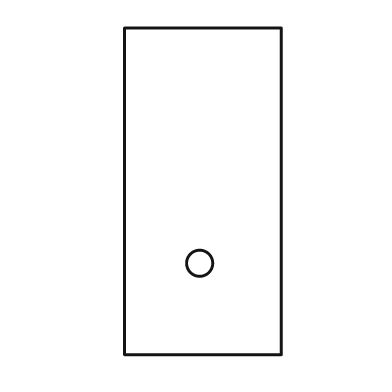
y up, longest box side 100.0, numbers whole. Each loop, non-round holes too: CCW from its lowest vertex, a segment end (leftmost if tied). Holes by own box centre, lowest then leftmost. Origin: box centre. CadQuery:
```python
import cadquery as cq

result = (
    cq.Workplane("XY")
    .moveTo(-24.0, -50.0)
    .lineTo(24.0, -50.0)
    .lineTo(24.0, 50.0)
    .lineTo(-24.0, 50.0)
    .close()
    .moveTo(-1.0, -22.0)
    .circle(4.0)
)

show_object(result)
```